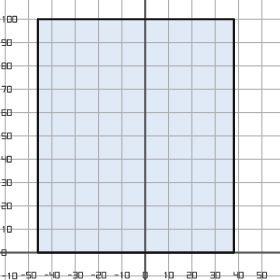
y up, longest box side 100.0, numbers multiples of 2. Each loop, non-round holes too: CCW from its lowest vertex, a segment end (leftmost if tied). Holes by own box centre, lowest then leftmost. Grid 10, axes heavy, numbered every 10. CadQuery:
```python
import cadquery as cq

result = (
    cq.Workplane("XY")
    .moveTo(-46.0, 0.0)
    .lineTo(38.0, 0.0)
    .lineTo(38.0, 100.0)
    .lineTo(-46.0, 100.0)
    .close()
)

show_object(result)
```